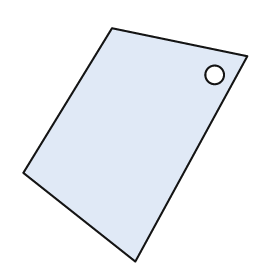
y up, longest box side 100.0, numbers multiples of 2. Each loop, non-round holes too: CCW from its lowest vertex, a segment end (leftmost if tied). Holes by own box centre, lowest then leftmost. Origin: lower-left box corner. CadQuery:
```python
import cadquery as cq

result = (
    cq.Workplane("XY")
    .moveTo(48.0, 0.0)
    .lineTo(96.0, 88.0)
    .lineTo(38.0, 100.0)
    .lineTo(0.0, 38.0)
    .close()
    .moveTo(82.0, 80.0)
    .circle(4.0)
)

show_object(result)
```